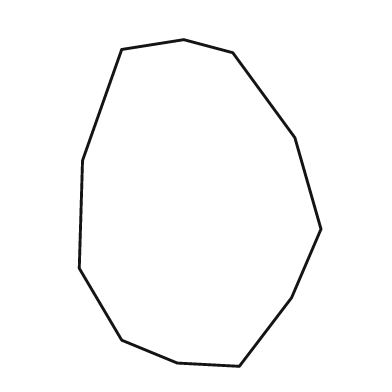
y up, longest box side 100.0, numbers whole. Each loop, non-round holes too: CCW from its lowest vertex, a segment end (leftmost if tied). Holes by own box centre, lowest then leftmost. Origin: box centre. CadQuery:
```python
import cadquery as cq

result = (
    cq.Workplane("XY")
    .moveTo(12.0, -50.0)
    .lineTo(28.0, -29.0)
    .lineTo(37.0, -8.0)
    .lineTo(29.0, 20.0)
    .lineTo(10.0, 46.0)
    .lineTo(-5.0, 50.0)
    .lineTo(-24.0, 47.0)
    .lineTo(-36.0, 13.0)
    .lineTo(-37.0, -20.0)
    .lineTo(-24.0, -42.0)
    .lineTo(-7.0, -49.0)
    .close()
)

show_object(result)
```